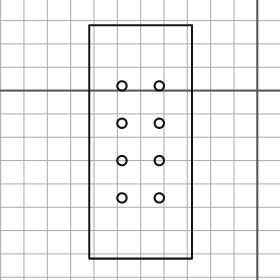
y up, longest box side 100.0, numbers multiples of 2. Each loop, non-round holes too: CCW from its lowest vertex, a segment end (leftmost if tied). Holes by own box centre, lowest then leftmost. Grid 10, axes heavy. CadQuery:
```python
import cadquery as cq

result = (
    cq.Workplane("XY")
    .moveTo(-72.0, -72.0)
    .lineTo(-28.0, -72.0)
    .lineTo(-28.0, 28.0)
    .lineTo(-72.0, 28.0)
    .close()
    .moveTo(-58.0, -46.0)
    .circle(2.0)
    .moveTo(-42.0, -46.0)
    .circle(2.0)
    .moveTo(-58.0, -30.0)
    .circle(2.0)
    .moveTo(-42.0, -30.0)
    .circle(2.0)
    .moveTo(-58.0, -14.0)
    .circle(2.0)
    .moveTo(-42.0, -14.0)
    .circle(2.0)
    .moveTo(-58.0, 2.0)
    .circle(2.0)
    .moveTo(-42.0, 2.0)
    .circle(2.0)
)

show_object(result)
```